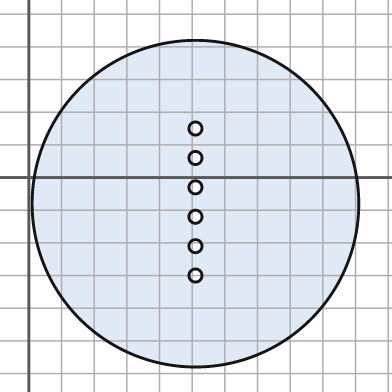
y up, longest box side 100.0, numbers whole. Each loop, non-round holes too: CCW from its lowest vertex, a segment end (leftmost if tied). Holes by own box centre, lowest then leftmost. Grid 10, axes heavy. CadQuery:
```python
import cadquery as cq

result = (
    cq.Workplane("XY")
    .moveTo(51.0, -8.0)
    .circle(50.0)
    .moveTo(51.0, -30.0)
    .circle(2.0)
    .moveTo(51.0, -21.0)
    .circle(2.0)
    .moveTo(51.0, -12.0)
    .circle(2.0)
    .moveTo(51.0, -3.0)
    .circle(2.0)
    .moveTo(51.0, 6.0)
    .circle(2.0)
    .moveTo(51.0, 15.0)
    .circle(2.0)
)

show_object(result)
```